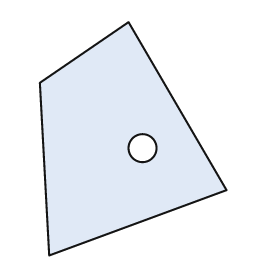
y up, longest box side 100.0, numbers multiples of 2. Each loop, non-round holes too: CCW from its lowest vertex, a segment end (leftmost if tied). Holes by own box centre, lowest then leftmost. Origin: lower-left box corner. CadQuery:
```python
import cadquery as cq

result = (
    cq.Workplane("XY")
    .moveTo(4.0, 0.0)
    .lineTo(80.0, 28.0)
    .lineTo(38.0, 100.0)
    .lineTo(0.0, 74.0)
    .close()
    .moveTo(44.0, 46.0)
    .circle(6.0)
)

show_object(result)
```